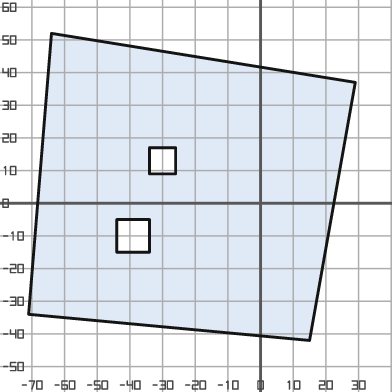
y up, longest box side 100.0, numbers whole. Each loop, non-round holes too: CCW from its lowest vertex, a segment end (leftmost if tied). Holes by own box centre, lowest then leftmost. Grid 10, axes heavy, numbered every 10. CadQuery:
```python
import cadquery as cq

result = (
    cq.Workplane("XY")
    .moveTo(15.0, -42.0)
    .lineTo(29.0, 37.0)
    .lineTo(-64.0, 52.0)
    .lineTo(-71.0, -34.0)
    .close()
    .moveTo(-44.0, -15.0)
    .lineTo(-34.0, -15.0)
    .lineTo(-34.0, -5.0)
    .lineTo(-44.0, -5.0)
    .close()
    .moveTo(-34.0, 9.0)
    .lineTo(-26.0, 9.0)
    .lineTo(-26.0, 17.0)
    .lineTo(-34.0, 17.0)
    .close()
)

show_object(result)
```